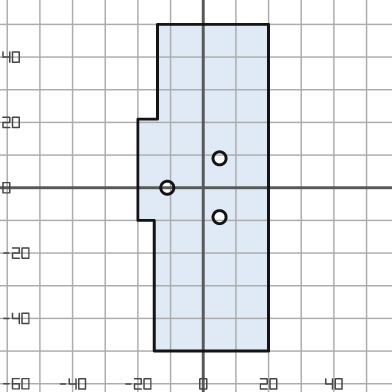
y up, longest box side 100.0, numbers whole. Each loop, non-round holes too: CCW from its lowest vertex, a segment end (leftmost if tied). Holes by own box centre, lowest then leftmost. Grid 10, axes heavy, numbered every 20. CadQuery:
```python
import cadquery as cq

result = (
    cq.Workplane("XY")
    .moveTo(-15.0, -50.0)
    .lineTo(20.0, -50.0)
    .lineTo(20.0, 50.0)
    .lineTo(-14.0, 50.0)
    .lineTo(-14.0, 21.0)
    .lineTo(-20.0, 21.0)
    .lineTo(-20.0, -10.0)
    .lineTo(-15.0, -10.0)
    .close()
    .moveTo(5.0, -9.0)
    .circle(2.0)
    .moveTo(-11.0, 0.0)
    .circle(2.0)
    .moveTo(5.0, 9.0)
    .circle(2.0)
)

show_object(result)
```